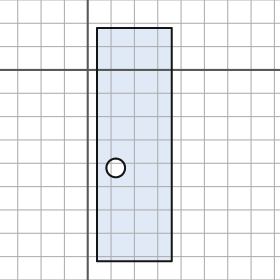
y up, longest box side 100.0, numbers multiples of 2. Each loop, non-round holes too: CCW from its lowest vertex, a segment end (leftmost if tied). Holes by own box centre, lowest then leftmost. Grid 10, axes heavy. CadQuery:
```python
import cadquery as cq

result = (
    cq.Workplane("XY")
    .moveTo(4.0, -82.0)
    .lineTo(36.0, -82.0)
    .lineTo(36.0, 18.0)
    .lineTo(4.0, 18.0)
    .close()
    .moveTo(12.0, -42.0)
    .circle(4.0)
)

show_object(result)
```